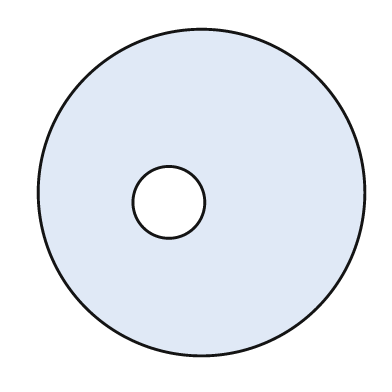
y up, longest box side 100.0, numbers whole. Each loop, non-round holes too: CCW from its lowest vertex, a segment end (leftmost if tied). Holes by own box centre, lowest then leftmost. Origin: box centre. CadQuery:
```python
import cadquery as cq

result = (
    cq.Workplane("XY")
    .moveTo(0.0, 0.0)
    .circle(50.0)
    .moveTo(-10.0, -3.0)
    .circle(11.0)
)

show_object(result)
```